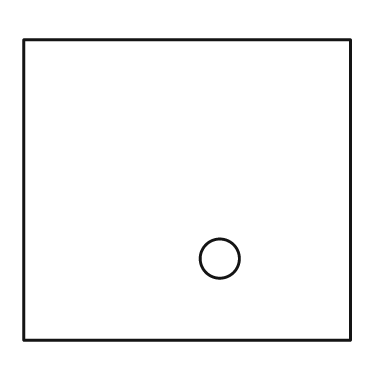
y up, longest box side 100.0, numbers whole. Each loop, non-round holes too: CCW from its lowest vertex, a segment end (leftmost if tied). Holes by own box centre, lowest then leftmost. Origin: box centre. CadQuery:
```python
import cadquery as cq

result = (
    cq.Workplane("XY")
    .moveTo(-50.0, -46.0)
    .lineTo(50.0, -46.0)
    .lineTo(50.0, 46.0)
    .lineTo(-50.0, 46.0)
    .close()
    .moveTo(10.0, -21.0)
    .circle(6.0)
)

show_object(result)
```